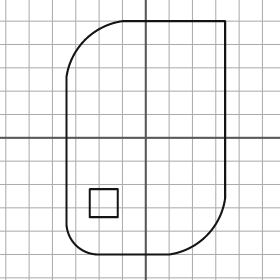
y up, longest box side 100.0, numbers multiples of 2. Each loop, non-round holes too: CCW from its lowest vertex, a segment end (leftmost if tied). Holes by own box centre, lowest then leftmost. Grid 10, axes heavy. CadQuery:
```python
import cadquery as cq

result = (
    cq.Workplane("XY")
    .moveTo(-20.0, -50.0)
    .lineTo(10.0, -50.0)
    .threePointArc((26.0, -42.0), (34.0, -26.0))
    .lineTo(34.0, 50.0)
    .lineTo(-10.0, 50.0)
    .threePointArc((-26.0, 42.0), (-34.0, 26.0))
    .lineTo(-34.0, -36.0)
    .threePointArc((-30.0, -46.0), (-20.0, -50.0))
    .close()
    .moveTo(-24.0, -34.0)
    .lineTo(-12.0, -34.0)
    .lineTo(-12.0, -22.0)
    .lineTo(-24.0, -22.0)
    .close()
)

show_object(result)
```